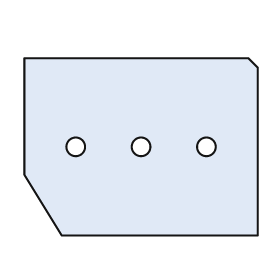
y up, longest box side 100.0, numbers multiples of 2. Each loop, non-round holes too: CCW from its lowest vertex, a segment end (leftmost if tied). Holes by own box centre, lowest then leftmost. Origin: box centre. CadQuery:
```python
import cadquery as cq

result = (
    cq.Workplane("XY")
    .moveTo(-34.0, -38.0)
    .lineTo(50.0, -38.0)
    .lineTo(50.0, 34.0)
    .lineTo(46.0, 38.0)
    .lineTo(-50.0, 38.0)
    .lineTo(-50.0, -12.0)
    .close()
    .moveTo(-28.0, 0.0)
    .circle(4.0)
    .moveTo(0.0, 0.0)
    .circle(4.0)
    .moveTo(28.0, 0.0)
    .circle(4.0)
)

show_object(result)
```